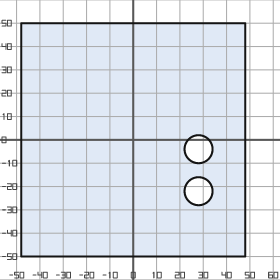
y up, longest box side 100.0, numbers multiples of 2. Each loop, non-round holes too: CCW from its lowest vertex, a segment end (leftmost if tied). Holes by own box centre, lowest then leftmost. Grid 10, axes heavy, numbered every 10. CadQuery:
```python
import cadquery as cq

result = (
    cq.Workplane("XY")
    .moveTo(-48.0, -50.0)
    .lineTo(48.0, -50.0)
    .lineTo(48.0, 50.0)
    .lineTo(-48.0, 50.0)
    .close()
    .moveTo(28.0, -22.0)
    .circle(6.0)
    .moveTo(28.0, -4.0)
    .circle(6.0)
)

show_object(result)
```